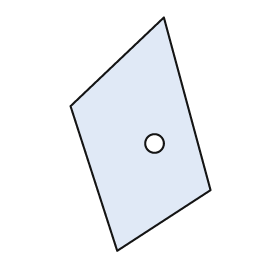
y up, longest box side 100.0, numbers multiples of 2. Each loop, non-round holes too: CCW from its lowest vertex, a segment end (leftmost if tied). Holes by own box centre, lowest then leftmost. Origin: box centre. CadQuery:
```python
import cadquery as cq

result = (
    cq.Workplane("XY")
    .moveTo(-10.0, -50.0)
    .lineTo(30.0, -24.0)
    .lineTo(10.0, 50.0)
    .lineTo(-30.0, 12.0)
    .close()
    .moveTo(6.0, -4.0)
    .circle(4.0)
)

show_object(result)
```